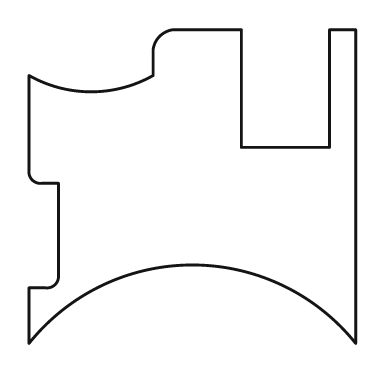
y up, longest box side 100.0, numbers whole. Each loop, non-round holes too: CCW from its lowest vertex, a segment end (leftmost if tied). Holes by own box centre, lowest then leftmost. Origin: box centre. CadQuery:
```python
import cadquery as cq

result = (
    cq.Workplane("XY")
    .moveTo(-50.0, -48.0)
    .threePointArc((0.0, -24.0), (50.0, -48.0))
    .lineTo(50.0, 48.0)
    .lineTo(42.0, 48.0)
    .lineTo(42.0, 12.0)
    .lineTo(15.0, 12.0)
    .lineTo(15.0, 48.0)
    .lineTo(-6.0, 48.0)
    .threePointArc((-10.0, 46.0), (-12.0, 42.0))
    .lineTo(-12.0, 34.0)
    .threePointArc((-31.0, 29.0), (-50.0, 34.0))
    .lineTo(-50.0, 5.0)
    .threePointArc((-49.0, 2.0), (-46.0, 1.0))
    .lineTo(-41.0, 1.0)
    .lineTo(-41.0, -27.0)
    .threePointArc((-42.0, -30.0), (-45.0, -31.0))
    .lineTo(-50.0, -31.0)
    .close()
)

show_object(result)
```